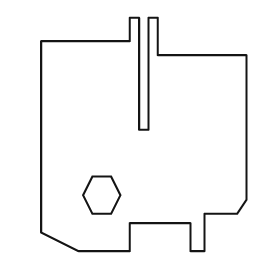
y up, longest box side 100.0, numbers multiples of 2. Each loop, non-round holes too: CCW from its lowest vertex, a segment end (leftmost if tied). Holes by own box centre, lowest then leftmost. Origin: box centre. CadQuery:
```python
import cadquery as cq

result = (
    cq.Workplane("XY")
    .moveTo(-28.0, -50.0)
    .lineTo(-6.0, -50.0)
    .lineTo(-6.0, -38.0)
    .lineTo(20.0, -38.0)
    .lineTo(20.0, -50.0)
    .lineTo(26.0, -50.0)
    .lineTo(26.0, -34.0)
    .lineTo(40.0, -34.0)
    .lineTo(44.0, -28.0)
    .lineTo(44.0, 34.0)
    .lineTo(6.0, 34.0)
    .lineTo(6.0, 50.0)
    .lineTo(2.0, 50.0)
    .lineTo(2.0, 2.0)
    .lineTo(-2.0, 2.0)
    .lineTo(-2.0, 50.0)
    .lineTo(-6.0, 50.0)
    .lineTo(-6.0, 40.0)
    .lineTo(-44.0, 40.0)
    .lineTo(-44.0, -42.0)
    .close()
    .moveTo(-22.0, -34.0)
    .lineTo(-14.0, -34.0)
    .lineTo(-10.0, -26.0)
    .lineTo(-14.0, -18.0)
    .lineTo(-22.0, -18.0)
    .lineTo(-26.0, -26.0)
    .close()
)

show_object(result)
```